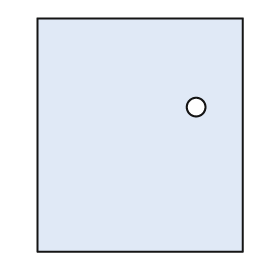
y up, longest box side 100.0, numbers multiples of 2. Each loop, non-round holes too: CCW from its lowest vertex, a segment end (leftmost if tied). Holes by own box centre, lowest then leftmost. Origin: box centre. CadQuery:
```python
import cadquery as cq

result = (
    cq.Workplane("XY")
    .moveTo(-44.0, -50.0)
    .lineTo(44.0, -50.0)
    .lineTo(44.0, 50.0)
    .lineTo(-44.0, 50.0)
    .close()
    .moveTo(24.0, 12.0)
    .circle(4.0)
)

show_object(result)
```